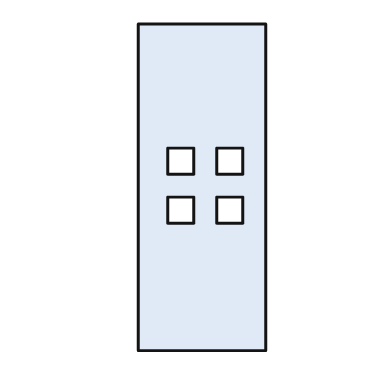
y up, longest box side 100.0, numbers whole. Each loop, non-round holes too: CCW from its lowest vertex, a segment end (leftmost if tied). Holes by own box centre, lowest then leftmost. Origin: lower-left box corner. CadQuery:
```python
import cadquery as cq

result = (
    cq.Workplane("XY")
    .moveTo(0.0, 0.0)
    .lineTo(39.0, 0.0)
    .lineTo(39.0, 100.0)
    .lineTo(0.0, 100.0)
    .close()
    .moveTo(9.0, 39.0)
    .lineTo(17.0, 39.0)
    .lineTo(17.0, 47.0)
    .lineTo(9.0, 47.0)
    .close()
    .moveTo(24.0, 39.0)
    .lineTo(32.0, 39.0)
    .lineTo(32.0, 47.0)
    .lineTo(24.0, 47.0)
    .close()
    .moveTo(9.0, 54.0)
    .lineTo(17.0, 54.0)
    .lineTo(17.0, 62.0)
    .lineTo(9.0, 62.0)
    .close()
    .moveTo(24.0, 54.0)
    .lineTo(32.0, 54.0)
    .lineTo(32.0, 62.0)
    .lineTo(24.0, 62.0)
    .close()
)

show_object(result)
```